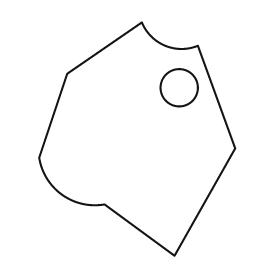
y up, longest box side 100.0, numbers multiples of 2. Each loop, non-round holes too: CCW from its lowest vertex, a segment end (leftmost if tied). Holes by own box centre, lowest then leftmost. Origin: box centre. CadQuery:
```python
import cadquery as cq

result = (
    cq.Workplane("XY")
    .moveTo(16.0, -50.0)
    .lineTo(42.0, -4.0)
    .lineTo(26.0, 40.0)
    .threePointArc((12.0, 40.0), (2.0, 50.0))
    .lineTo(-30.0, 28.0)
    .lineTo(-42.0, -8.0)
    .threePointArc((-32.0, -24.0), (-14.0, -28.0))
    .close()
    .moveTo(18.0, 22.0)
    .circle(8.0)
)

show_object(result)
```